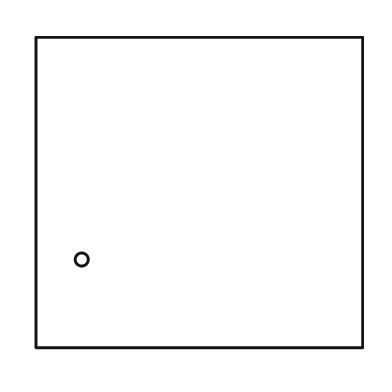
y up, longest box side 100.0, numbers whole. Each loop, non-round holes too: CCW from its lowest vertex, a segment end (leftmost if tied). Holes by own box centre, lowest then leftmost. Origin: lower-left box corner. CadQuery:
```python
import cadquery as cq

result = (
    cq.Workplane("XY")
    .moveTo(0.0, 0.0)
    .lineTo(100.0, 0.0)
    .lineTo(100.0, 95.0)
    .lineTo(0.0, 95.0)
    .close()
    .moveTo(14.0, 27.0)
    .circle(2.0)
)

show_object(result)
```